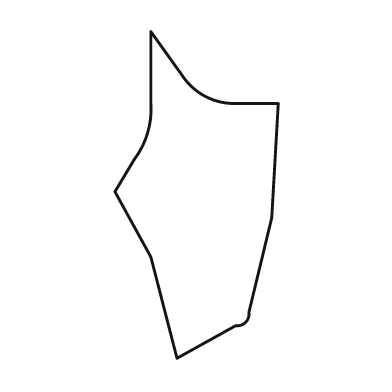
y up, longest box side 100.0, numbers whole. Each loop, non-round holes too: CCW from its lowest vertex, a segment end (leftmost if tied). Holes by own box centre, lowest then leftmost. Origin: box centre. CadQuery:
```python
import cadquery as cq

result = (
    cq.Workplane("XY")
    .moveTo(-6.0, -50.0)
    .lineTo(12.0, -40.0)
    .threePointArc((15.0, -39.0), (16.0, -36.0))
    .lineTo(23.0, -7.0)
    .lineTo(25.0, 28.0)
    .lineTo(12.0, 28.0)
    .threePointArc((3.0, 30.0), (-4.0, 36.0))
    .lineTo(-14.0, 50.0)
    .lineTo(-14.0, 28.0)
    .threePointArc((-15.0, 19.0), (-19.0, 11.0))
    .lineTo(-25.0, 1.0)
    .lineTo(-14.0, -19.0)
    .close()
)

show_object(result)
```